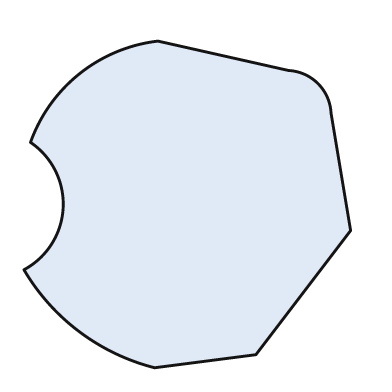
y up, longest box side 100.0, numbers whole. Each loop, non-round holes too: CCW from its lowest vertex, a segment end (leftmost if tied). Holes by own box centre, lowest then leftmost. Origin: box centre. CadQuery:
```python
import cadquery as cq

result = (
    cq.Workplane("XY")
    .moveTo(-10.0, -50.0)
    .lineTo(21.0, -46.0)
    .lineTo(50.0, -8.0)
    .lineTo(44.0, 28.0)
    .threePointArc((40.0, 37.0), (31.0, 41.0))
    .lineTo(-9.0, 50.0)
    .threePointArc((-33.0, 40.0), (-48.0, 19.0))
    .threePointArc((-38.0, -1.0), (-50.0, -20.0))
    .threePointArc((-33.0, -39.0), (-10.0, -50.0))
    .close()
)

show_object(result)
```